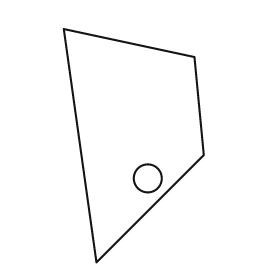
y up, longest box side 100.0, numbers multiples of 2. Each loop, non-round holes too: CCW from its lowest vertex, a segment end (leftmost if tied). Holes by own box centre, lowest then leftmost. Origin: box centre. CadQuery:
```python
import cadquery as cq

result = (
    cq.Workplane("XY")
    .moveTo(-16.0, -50.0)
    .lineTo(30.0, -4.0)
    .lineTo(26.0, 38.0)
    .lineTo(-30.0, 50.0)
    .close()
    .moveTo(6.0, -14.0)
    .circle(6.0)
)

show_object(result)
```